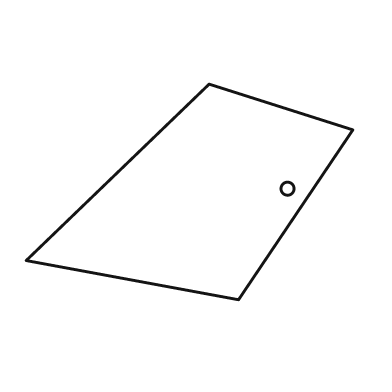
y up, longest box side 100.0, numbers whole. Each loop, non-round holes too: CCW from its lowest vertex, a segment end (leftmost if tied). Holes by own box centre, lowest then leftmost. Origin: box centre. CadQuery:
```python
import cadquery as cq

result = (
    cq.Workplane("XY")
    .moveTo(15.0, -33.0)
    .lineTo(50.0, 19.0)
    .lineTo(6.0, 33.0)
    .lineTo(-50.0, -21.0)
    .close()
    .moveTo(30.0, 1.0)
    .circle(2.0)
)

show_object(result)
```